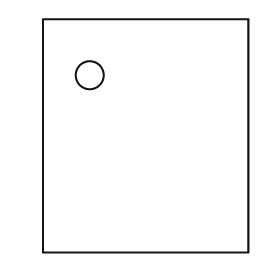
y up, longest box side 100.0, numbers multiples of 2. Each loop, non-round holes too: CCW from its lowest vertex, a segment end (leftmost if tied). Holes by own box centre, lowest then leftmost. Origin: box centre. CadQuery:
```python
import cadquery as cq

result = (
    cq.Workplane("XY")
    .moveTo(-44.0, -50.0)
    .lineTo(44.0, -50.0)
    .lineTo(44.0, 50.0)
    .lineTo(-44.0, 50.0)
    .close()
    .moveTo(-24.0, 26.0)
    .circle(6.0)
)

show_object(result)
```